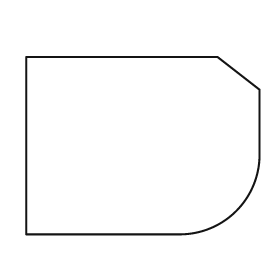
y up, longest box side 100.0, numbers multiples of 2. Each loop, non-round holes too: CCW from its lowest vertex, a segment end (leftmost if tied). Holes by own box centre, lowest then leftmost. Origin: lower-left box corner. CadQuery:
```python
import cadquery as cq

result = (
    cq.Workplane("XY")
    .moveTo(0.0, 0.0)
    .lineTo(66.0, 0.0)
    .threePointArc((90.0, 10.0), (100.0, 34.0))
    .lineTo(100.0, 62.0)
    .lineTo(82.0, 76.0)
    .lineTo(0.0, 76.0)
    .close()
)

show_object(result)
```